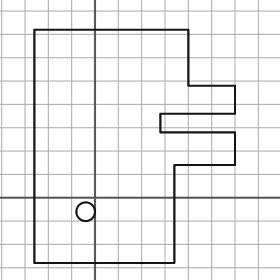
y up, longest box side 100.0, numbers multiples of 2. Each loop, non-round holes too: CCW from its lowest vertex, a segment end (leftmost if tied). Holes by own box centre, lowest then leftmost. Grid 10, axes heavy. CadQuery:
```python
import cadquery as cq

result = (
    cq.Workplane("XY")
    .moveTo(-26.0, -28.0)
    .lineTo(34.0, -28.0)
    .lineTo(34.0, 14.0)
    .lineTo(60.0, 14.0)
    .lineTo(60.0, 28.0)
    .lineTo(28.0, 28.0)
    .lineTo(28.0, 36.0)
    .lineTo(60.0, 36.0)
    .lineTo(60.0, 48.0)
    .lineTo(40.0, 48.0)
    .lineTo(40.0, 72.0)
    .lineTo(-26.0, 72.0)
    .close()
    .moveTo(-4.0, -6.0)
    .circle(4.0)
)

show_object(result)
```